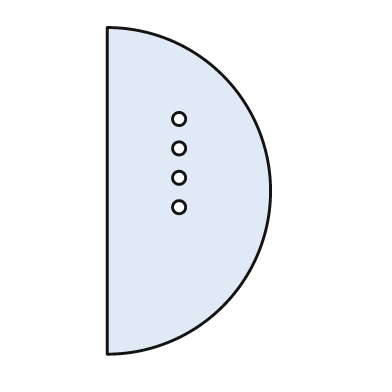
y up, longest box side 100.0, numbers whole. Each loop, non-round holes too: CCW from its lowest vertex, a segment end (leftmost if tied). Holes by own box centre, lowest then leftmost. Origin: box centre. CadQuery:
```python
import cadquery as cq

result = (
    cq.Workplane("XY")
    .moveTo(-25.0, -50.0)
    .threePointArc((25.0, 0.0), (-25.0, 50.0))
    .close()
    .moveTo(-3.0, -5.0)
    .circle(2.0)
    .moveTo(-3.0, 4.0)
    .circle(2.0)
    .moveTo(-3.0, 13.0)
    .circle(2.0)
    .moveTo(-3.0, 22.0)
    .circle(2.0)
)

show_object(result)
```